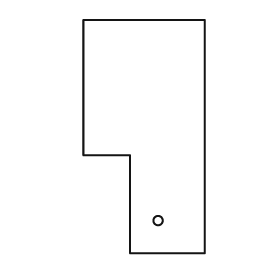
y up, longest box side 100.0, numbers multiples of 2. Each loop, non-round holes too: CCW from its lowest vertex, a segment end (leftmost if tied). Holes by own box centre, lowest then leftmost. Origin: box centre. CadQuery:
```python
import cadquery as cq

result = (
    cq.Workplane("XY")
    .moveTo(-6.0, -50.0)
    .lineTo(26.0, -50.0)
    .lineTo(26.0, 50.0)
    .lineTo(-26.0, 50.0)
    .lineTo(-26.0, -8.0)
    .lineTo(-6.0, -8.0)
    .close()
    .moveTo(6.0, -36.0)
    .circle(2.0)
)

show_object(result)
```